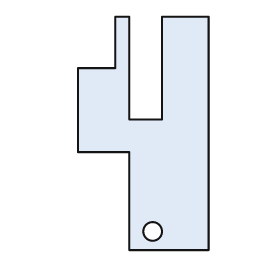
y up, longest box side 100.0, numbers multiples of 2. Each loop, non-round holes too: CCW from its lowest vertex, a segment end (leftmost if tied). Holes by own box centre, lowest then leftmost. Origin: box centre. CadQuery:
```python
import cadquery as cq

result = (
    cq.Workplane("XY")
    .moveTo(-6.0, -50.0)
    .lineTo(28.0, -50.0)
    .lineTo(28.0, 50.0)
    .lineTo(8.0, 50.0)
    .lineTo(8.0, 6.0)
    .lineTo(-6.0, 6.0)
    .lineTo(-6.0, 50.0)
    .lineTo(-12.0, 50.0)
    .lineTo(-12.0, 28.0)
    .lineTo(-28.0, 28.0)
    .lineTo(-28.0, -8.0)
    .lineTo(-6.0, -8.0)
    .close()
    .moveTo(4.0, -42.0)
    .circle(4.0)
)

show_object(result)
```